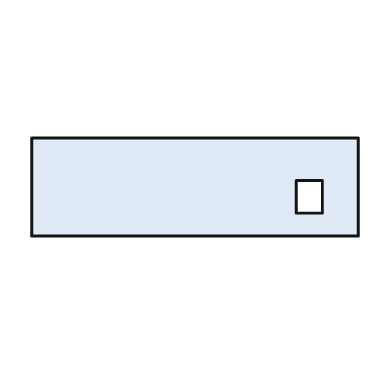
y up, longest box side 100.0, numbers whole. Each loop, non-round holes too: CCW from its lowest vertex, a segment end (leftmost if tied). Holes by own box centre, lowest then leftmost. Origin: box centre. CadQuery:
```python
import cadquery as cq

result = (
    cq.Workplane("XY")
    .moveTo(-50.0, -15.0)
    .lineTo(50.0, -15.0)
    .lineTo(50.0, 15.0)
    .lineTo(-50.0, 15.0)
    .close()
    .moveTo(31.0, -8.0)
    .lineTo(39.0, -8.0)
    .lineTo(39.0, 2.0)
    .lineTo(31.0, 2.0)
    .close()
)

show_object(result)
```